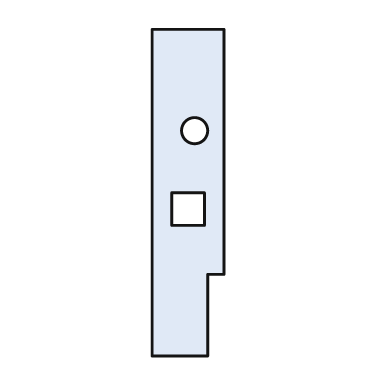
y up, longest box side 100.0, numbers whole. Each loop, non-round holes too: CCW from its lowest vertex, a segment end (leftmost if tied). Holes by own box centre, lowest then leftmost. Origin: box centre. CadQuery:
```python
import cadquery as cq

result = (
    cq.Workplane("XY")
    .moveTo(-11.0, -50.0)
    .lineTo(6.0, -50.0)
    .lineTo(6.0, -25.0)
    .lineTo(11.0, -25.0)
    .lineTo(11.0, 50.0)
    .lineTo(-11.0, 50.0)
    .close()
    .moveTo(-5.0, -10.0)
    .lineTo(5.0, -10.0)
    .lineTo(5.0, 0.0)
    .lineTo(-5.0, 0.0)
    .close()
    .moveTo(2.0, 19.0)
    .circle(4.0)
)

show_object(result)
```